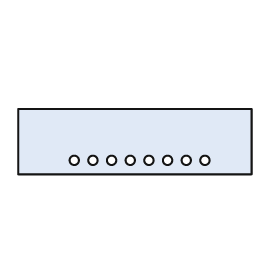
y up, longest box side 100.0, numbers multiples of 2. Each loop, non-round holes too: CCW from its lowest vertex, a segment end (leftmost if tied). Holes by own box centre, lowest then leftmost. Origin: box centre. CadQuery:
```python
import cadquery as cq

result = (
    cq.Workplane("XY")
    .moveTo(-50.0, -14.0)
    .lineTo(50.0, -14.0)
    .lineTo(50.0, 14.0)
    .lineTo(-50.0, 14.0)
    .close()
    .moveTo(-26.0, -8.0)
    .circle(2.0)
    .moveTo(-18.0, -8.0)
    .circle(2.0)
    .moveTo(-10.0, -8.0)
    .circle(2.0)
    .moveTo(-2.0, -8.0)
    .circle(2.0)
    .moveTo(6.0, -8.0)
    .circle(2.0)
    .moveTo(14.0, -8.0)
    .circle(2.0)
    .moveTo(22.0, -8.0)
    .circle(2.0)
    .moveTo(30.0, -8.0)
    .circle(2.0)
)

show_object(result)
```